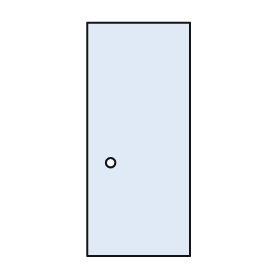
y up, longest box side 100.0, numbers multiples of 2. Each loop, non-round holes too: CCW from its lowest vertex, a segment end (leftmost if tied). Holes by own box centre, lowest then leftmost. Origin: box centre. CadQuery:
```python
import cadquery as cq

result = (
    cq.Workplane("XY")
    .moveTo(-22.0, -50.0)
    .lineTo(22.0, -50.0)
    .lineTo(22.0, 50.0)
    .lineTo(-22.0, 50.0)
    .close()
    .moveTo(-12.0, -10.0)
    .circle(2.0)
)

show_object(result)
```